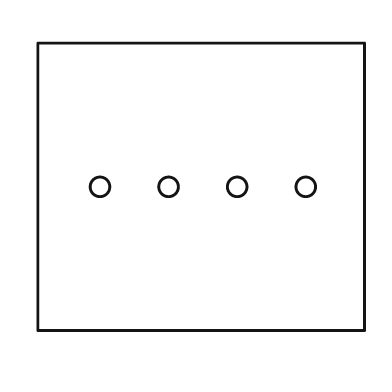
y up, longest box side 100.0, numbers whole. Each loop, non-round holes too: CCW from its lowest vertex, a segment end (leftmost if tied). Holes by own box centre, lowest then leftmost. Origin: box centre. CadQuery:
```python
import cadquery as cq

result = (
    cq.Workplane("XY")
    .moveTo(-50.0, -44.0)
    .lineTo(50.0, -44.0)
    .lineTo(50.0, 44.0)
    .lineTo(-50.0, 44.0)
    .close()
    .moveTo(-31.0, 0.0)
    .circle(3.0)
    .moveTo(-10.0, 0.0)
    .circle(3.0)
    .moveTo(11.0, 0.0)
    .circle(3.0)
    .moveTo(32.0, 0.0)
    .circle(3.0)
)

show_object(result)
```